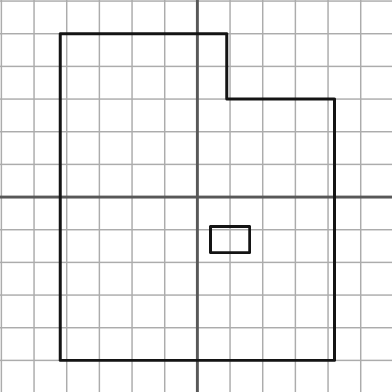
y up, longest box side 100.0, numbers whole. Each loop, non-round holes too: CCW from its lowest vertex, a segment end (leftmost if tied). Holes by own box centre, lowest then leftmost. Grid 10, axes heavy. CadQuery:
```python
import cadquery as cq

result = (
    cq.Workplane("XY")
    .moveTo(-42.0, -50.0)
    .lineTo(42.0, -50.0)
    .lineTo(42.0, 30.0)
    .lineTo(9.0, 30.0)
    .lineTo(9.0, 50.0)
    .lineTo(-42.0, 50.0)
    .close()
    .moveTo(4.0, -17.0)
    .lineTo(16.0, -17.0)
    .lineTo(16.0, -9.0)
    .lineTo(4.0, -9.0)
    .close()
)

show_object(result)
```